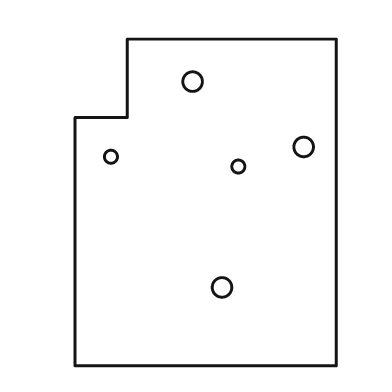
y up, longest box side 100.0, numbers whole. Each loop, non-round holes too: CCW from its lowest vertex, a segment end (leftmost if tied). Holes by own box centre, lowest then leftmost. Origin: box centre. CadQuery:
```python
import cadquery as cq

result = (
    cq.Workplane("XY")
    .moveTo(-40.0, -50.0)
    .lineTo(40.0, -50.0)
    .lineTo(40.0, 50.0)
    .lineTo(-24.0, 50.0)
    .lineTo(-24.0, 26.0)
    .lineTo(-40.0, 26.0)
    .close()
    .moveTo(5.0, -26.0)
    .circle(3.0)
    .moveTo(10.0, 11.0)
    .circle(2.0)
    .moveTo(-29.0, 14.0)
    .circle(2.0)
    .moveTo(30.0, 17.0)
    .circle(3.0)
    .moveTo(-4.0, 37.0)
    .circle(3.0)
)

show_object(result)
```